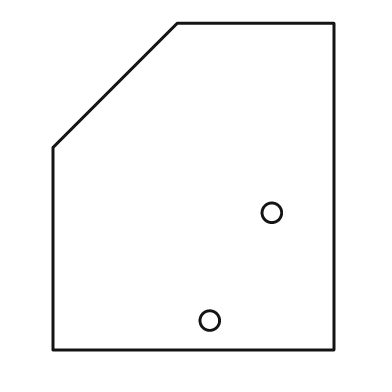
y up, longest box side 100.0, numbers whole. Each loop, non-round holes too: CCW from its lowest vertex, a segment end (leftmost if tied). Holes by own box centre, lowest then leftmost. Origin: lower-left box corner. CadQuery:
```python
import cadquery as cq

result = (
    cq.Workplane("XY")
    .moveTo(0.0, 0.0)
    .lineTo(86.0, 0.0)
    .lineTo(86.0, 100.0)
    .lineTo(38.0, 100.0)
    .lineTo(0.0, 62.0)
    .close()
    .moveTo(48.0, 9.0)
    .circle(3.0)
    .moveTo(67.0, 42.0)
    .circle(3.0)
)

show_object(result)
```